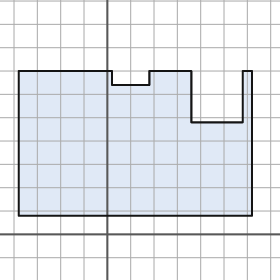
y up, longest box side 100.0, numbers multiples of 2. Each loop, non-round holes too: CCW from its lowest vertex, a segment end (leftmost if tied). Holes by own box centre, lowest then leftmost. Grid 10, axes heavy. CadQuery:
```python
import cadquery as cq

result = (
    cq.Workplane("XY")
    .moveTo(-38.0, 8.0)
    .lineTo(62.0, 8.0)
    .lineTo(62.0, 70.0)
    .lineTo(58.0, 70.0)
    .lineTo(58.0, 48.0)
    .lineTo(36.0, 48.0)
    .lineTo(36.0, 70.0)
    .lineTo(18.0, 70.0)
    .lineTo(18.0, 64.0)
    .lineTo(2.0, 64.0)
    .lineTo(2.0, 70.0)
    .lineTo(-38.0, 70.0)
    .close()
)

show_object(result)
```